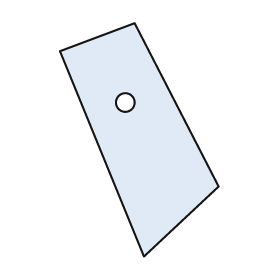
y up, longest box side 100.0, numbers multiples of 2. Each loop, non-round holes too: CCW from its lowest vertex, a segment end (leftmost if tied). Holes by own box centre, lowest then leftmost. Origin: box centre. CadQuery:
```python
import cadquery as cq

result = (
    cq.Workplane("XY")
    .moveTo(2.0, -50.0)
    .lineTo(34.0, -20.0)
    .lineTo(-2.0, 50.0)
    .lineTo(-34.0, 38.0)
    .close()
    .moveTo(-6.0, 16.0)
    .circle(4.0)
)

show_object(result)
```